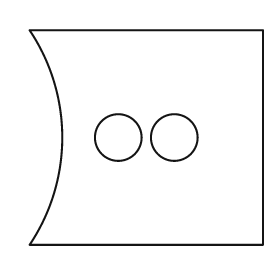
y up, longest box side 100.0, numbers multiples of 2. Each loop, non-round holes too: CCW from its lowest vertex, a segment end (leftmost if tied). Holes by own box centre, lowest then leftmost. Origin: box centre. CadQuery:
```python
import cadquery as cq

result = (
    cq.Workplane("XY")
    .moveTo(-50.0, -46.0)
    .lineTo(50.0, -46.0)
    .lineTo(50.0, 46.0)
    .lineTo(-50.0, 46.0)
    .threePointArc((-36.0, 0.0), (-50.0, -46.0))
    .close()
    .moveTo(-12.0, 0.0)
    .circle(10.0)
    .moveTo(12.0, 0.0)
    .circle(10.0)
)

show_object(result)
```